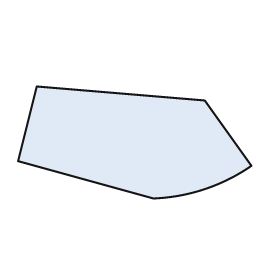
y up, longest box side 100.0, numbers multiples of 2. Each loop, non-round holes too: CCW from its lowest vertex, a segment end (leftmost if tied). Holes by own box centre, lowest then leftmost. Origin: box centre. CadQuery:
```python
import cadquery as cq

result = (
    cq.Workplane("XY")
    .moveTo(8.0, -24.0)
    .threePointArc((30.0, -20.0), (50.0, -10.0))
    .lineTo(30.0, 18.0)
    .lineTo(-42.0, 24.0)
    .lineTo(-50.0, -8.0)
    .close()
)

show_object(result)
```